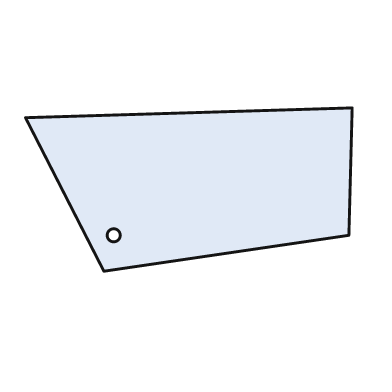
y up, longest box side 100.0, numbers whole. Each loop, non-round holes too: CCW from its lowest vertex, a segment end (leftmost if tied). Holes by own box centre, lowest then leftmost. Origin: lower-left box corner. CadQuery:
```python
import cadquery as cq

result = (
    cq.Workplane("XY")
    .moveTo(24.0, 0.0)
    .lineTo(99.0, 11.0)
    .lineTo(100.0, 50.0)
    .lineTo(0.0, 47.0)
    .close()
    .moveTo(27.0, 11.0)
    .circle(2.0)
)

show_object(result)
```